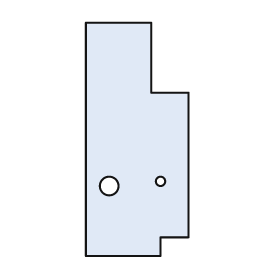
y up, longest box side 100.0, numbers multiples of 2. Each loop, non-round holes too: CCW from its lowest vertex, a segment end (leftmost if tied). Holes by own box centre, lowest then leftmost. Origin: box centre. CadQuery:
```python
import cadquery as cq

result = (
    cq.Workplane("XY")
    .moveTo(-22.0, -50.0)
    .lineTo(10.0, -50.0)
    .lineTo(10.0, -42.0)
    .lineTo(22.0, -42.0)
    .lineTo(22.0, 20.0)
    .lineTo(6.0, 20.0)
    .lineTo(6.0, 50.0)
    .lineTo(-22.0, 50.0)
    .close()
    .moveTo(-12.0, -20.0)
    .circle(4.0)
    .moveTo(10.0, -18.0)
    .circle(2.0)
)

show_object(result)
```